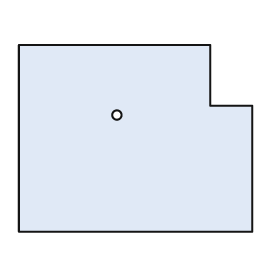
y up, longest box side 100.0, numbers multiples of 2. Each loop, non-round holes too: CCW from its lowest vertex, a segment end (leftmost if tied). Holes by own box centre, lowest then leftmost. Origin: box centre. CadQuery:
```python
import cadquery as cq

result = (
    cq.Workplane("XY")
    .moveTo(-50.0, -40.0)
    .lineTo(50.0, -40.0)
    .lineTo(50.0, 14.0)
    .lineTo(32.0, 14.0)
    .lineTo(32.0, 40.0)
    .lineTo(-50.0, 40.0)
    .close()
    .moveTo(-8.0, 10.0)
    .circle(2.0)
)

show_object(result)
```